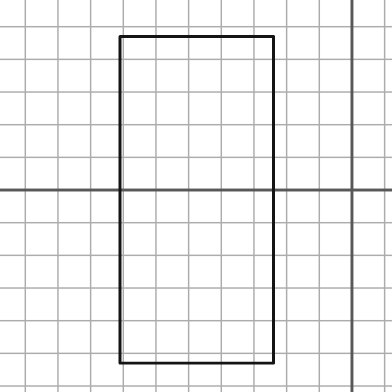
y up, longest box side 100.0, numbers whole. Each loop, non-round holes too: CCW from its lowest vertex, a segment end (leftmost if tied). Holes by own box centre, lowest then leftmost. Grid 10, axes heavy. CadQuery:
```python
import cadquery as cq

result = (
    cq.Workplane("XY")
    .moveTo(-71.0, -53.0)
    .lineTo(-24.0, -53.0)
    .lineTo(-24.0, 47.0)
    .lineTo(-71.0, 47.0)
    .close()
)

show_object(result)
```